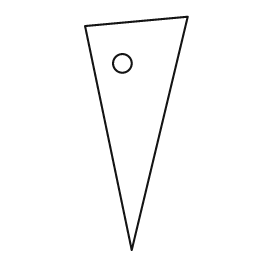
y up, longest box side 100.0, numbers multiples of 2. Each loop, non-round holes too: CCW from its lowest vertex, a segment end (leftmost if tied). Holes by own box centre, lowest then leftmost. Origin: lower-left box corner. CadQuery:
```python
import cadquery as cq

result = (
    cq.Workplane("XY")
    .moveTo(20.0, 0.0)
    .lineTo(44.0, 100.0)
    .lineTo(0.0, 96.0)
    .close()
    .moveTo(16.0, 80.0)
    .circle(4.0)
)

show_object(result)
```